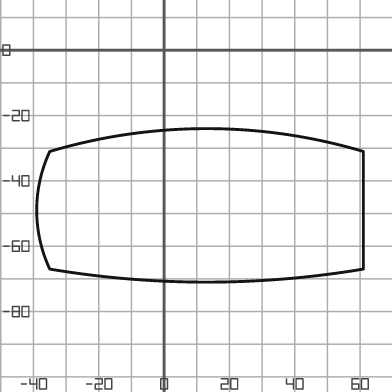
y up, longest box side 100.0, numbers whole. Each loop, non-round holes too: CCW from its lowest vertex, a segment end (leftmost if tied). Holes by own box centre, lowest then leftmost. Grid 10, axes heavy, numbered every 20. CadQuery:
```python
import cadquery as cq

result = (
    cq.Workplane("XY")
    .moveTo(-35.0, -67.0)
    .threePointArc((13.0, -71.0), (61.0, -67.0))
    .lineTo(61.0, -31.0)
    .threePointArc((13.0, -24.0), (-35.0, -31.0))
    .threePointArc((-39.0, -49.0), (-35.0, -67.0))
    .close()
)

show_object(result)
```